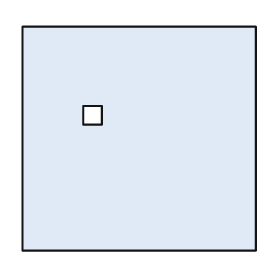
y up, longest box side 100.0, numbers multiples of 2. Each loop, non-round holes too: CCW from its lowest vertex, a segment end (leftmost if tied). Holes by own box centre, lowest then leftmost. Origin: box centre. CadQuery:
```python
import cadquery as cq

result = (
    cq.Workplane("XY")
    .moveTo(-50.0, -48.0)
    .lineTo(50.0, -48.0)
    .lineTo(50.0, 48.0)
    .lineTo(-50.0, 48.0)
    .close()
    .moveTo(-24.0, 6.0)
    .lineTo(-16.0, 6.0)
    .lineTo(-16.0, 14.0)
    .lineTo(-24.0, 14.0)
    .close()
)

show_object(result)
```